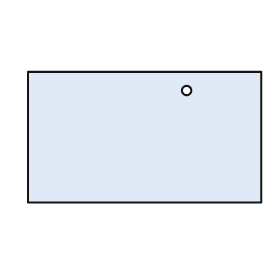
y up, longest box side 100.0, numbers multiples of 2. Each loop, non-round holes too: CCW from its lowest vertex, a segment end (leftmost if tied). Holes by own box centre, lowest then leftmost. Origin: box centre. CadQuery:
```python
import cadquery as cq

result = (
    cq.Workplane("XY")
    .moveTo(-50.0, -28.0)
    .lineTo(50.0, -28.0)
    .lineTo(50.0, 28.0)
    .lineTo(-50.0, 28.0)
    .close()
    .moveTo(18.0, 20.0)
    .circle(2.0)
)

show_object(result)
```